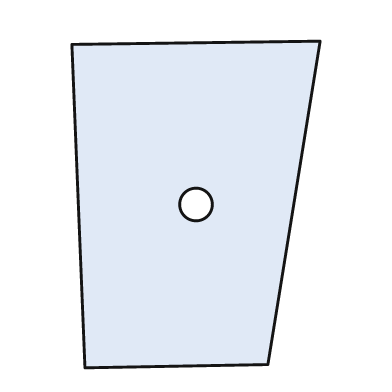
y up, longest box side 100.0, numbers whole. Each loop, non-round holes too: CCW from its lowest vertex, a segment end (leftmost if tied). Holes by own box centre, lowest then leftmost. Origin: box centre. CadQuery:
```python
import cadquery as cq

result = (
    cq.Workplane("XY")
    .moveTo(-34.0, -50.0)
    .lineTo(22.0, -49.0)
    .lineTo(38.0, 50.0)
    .lineTo(-38.0, 49.0)
    .close()
    .moveTo(0.0, 0.0)
    .circle(5.0)
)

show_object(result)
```